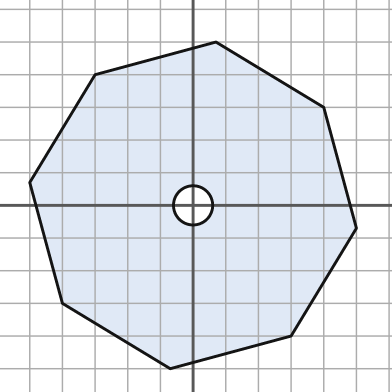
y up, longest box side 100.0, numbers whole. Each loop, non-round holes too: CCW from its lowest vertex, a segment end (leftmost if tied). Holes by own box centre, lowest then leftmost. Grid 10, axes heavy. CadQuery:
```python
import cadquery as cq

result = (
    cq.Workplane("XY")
    .moveTo(-7.0, -50.0)
    .lineTo(30.0, -40.0)
    .lineTo(50.0, -7.0)
    .lineTo(40.0, 30.0)
    .lineTo(7.0, 50.0)
    .lineTo(-30.0, 40.0)
    .lineTo(-50.0, 7.0)
    .lineTo(-40.0, -30.0)
    .close()
    .moveTo(0.0, 0.0)
    .circle(6.0)
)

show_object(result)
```